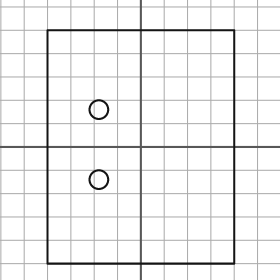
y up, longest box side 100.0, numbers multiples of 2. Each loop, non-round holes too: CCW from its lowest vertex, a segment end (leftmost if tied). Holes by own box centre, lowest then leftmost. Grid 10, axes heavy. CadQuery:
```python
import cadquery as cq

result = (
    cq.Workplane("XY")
    .moveTo(-40.0, -50.0)
    .lineTo(40.0, -50.0)
    .lineTo(40.0, 50.0)
    .lineTo(-40.0, 50.0)
    .close()
    .moveTo(-18.0, -14.0)
    .circle(4.0)
    .moveTo(-18.0, 16.0)
    .circle(4.0)
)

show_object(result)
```